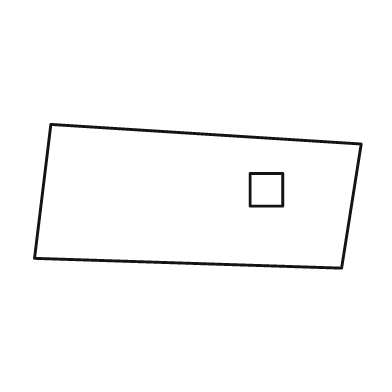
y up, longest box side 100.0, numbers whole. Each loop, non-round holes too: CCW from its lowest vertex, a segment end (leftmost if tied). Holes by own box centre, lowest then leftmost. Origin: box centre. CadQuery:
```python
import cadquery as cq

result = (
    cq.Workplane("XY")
    .moveTo(44.0, -22.0)
    .lineTo(50.0, 16.0)
    .lineTo(-45.0, 22.0)
    .lineTo(-50.0, -19.0)
    .close()
    .moveTo(16.0, -3.0)
    .lineTo(26.0, -3.0)
    .lineTo(26.0, 7.0)
    .lineTo(16.0, 7.0)
    .close()
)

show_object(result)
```